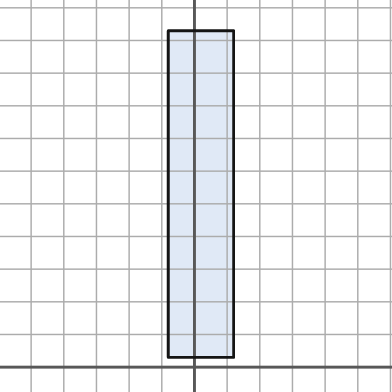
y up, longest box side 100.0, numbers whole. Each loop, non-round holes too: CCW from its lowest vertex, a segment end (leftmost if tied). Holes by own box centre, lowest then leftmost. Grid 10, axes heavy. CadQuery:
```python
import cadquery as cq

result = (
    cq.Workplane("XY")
    .moveTo(-8.0, 3.0)
    .lineTo(12.0, 3.0)
    .lineTo(12.0, 103.0)
    .lineTo(-8.0, 103.0)
    .close()
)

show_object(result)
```